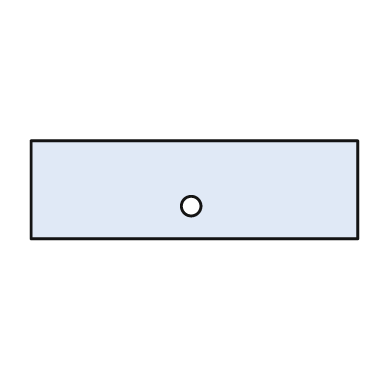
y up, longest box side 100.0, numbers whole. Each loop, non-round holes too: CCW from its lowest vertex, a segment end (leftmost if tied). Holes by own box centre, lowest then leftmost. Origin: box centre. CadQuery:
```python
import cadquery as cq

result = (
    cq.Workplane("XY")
    .moveTo(-50.0, -15.0)
    .lineTo(50.0, -15.0)
    .lineTo(50.0, 15.0)
    .lineTo(-50.0, 15.0)
    .close()
    .moveTo(-1.0, -5.0)
    .circle(3.0)
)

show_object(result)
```